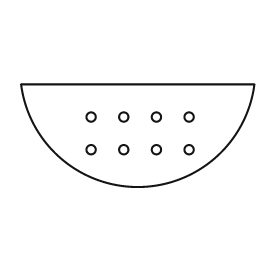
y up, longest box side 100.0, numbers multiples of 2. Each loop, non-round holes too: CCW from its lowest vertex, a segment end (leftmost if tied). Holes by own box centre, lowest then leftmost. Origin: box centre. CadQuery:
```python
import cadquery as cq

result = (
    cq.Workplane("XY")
    .moveTo(-50.0, 22.0)
    .threePointArc((0.0, -22.0), (50.0, 22.0))
    .close()
    .moveTo(-20.0, -6.0)
    .circle(2.0)
    .moveTo(-6.0, -6.0)
    .circle(2.0)
    .moveTo(8.0, -6.0)
    .circle(2.0)
    .moveTo(22.0, -6.0)
    .circle(2.0)
    .moveTo(-20.0, 8.0)
    .circle(2.0)
    .moveTo(-6.0, 8.0)
    .circle(2.0)
    .moveTo(8.0, 8.0)
    .circle(2.0)
    .moveTo(22.0, 8.0)
    .circle(2.0)
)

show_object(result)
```